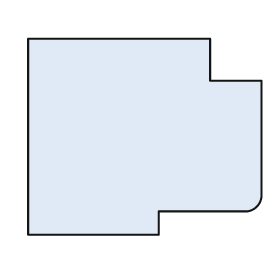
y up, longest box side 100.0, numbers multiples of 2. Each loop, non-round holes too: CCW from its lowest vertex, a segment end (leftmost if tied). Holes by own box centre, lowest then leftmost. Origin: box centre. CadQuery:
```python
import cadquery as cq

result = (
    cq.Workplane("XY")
    .moveTo(-50.0, -42.0)
    .lineTo(6.0, -42.0)
    .lineTo(6.0, -32.0)
    .lineTo(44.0, -32.0)
    .threePointArc((48.0, -30.0), (50.0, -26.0))
    .lineTo(50.0, 24.0)
    .lineTo(28.0, 24.0)
    .lineTo(28.0, 42.0)
    .lineTo(-50.0, 42.0)
    .close()
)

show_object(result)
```